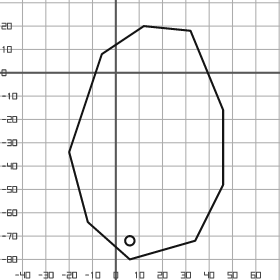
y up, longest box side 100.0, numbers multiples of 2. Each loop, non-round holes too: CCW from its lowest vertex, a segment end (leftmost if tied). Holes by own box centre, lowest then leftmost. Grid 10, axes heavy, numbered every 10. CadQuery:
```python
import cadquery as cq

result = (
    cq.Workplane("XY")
    .moveTo(6.0, -80.0)
    .lineTo(34.0, -72.0)
    .lineTo(46.0, -48.0)
    .lineTo(46.0, -16.0)
    .lineTo(32.0, 18.0)
    .lineTo(12.0, 20.0)
    .lineTo(-6.0, 8.0)
    .lineTo(-20.0, -34.0)
    .lineTo(-12.0, -64.0)
    .close()
    .moveTo(6.0, -72.0)
    .circle(2.0)
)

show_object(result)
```